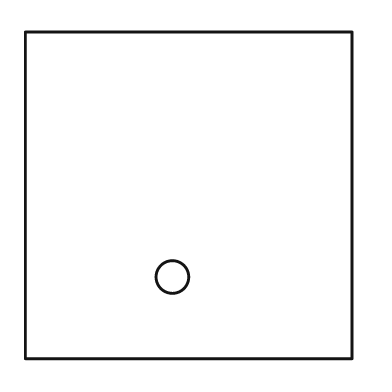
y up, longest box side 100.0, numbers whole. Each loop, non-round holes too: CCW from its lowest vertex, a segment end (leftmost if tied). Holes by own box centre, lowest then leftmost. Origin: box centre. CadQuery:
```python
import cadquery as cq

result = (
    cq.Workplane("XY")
    .moveTo(-50.0, -50.0)
    .lineTo(50.0, -50.0)
    .lineTo(50.0, 50.0)
    .lineTo(-50.0, 50.0)
    .close()
    .moveTo(-5.0, -25.0)
    .circle(5.0)
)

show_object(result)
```